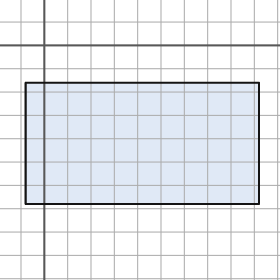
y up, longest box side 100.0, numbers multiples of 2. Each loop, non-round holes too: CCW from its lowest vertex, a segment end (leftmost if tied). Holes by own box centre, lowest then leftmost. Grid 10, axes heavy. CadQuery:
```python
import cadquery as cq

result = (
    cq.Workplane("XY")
    .moveTo(-8.0, -68.0)
    .lineTo(92.0, -68.0)
    .lineTo(92.0, -16.0)
    .lineTo(-8.0, -16.0)
    .close()
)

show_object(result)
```